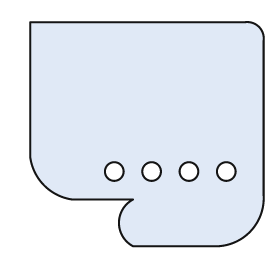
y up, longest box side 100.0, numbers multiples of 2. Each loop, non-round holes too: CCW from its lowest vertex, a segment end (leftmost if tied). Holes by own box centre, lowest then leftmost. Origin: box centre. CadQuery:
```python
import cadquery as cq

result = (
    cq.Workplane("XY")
    .moveTo(-6.0, -48.0)
    .lineTo(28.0, -48.0)
    .threePointArc((44.0, -42.0), (50.0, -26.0))
    .lineTo(50.0, 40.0)
    .threePointArc((48.0, 46.0), (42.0, 48.0))
    .lineTo(-50.0, 48.0)
    .lineTo(-50.0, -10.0)
    .threePointArc((-44.0, -22.0), (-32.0, -28.0))
    .lineTo(-6.0, -28.0)
    .threePointArc((-12.0, -38.0), (-6.0, -48.0))
    .close()
    .moveTo(-14.0, -16.0)
    .circle(4.0)
    .moveTo(2.0, -16.0)
    .circle(4.0)
    .moveTo(18.0, -16.0)
    .circle(4.0)
    .moveTo(34.0, -16.0)
    .circle(4.0)
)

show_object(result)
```